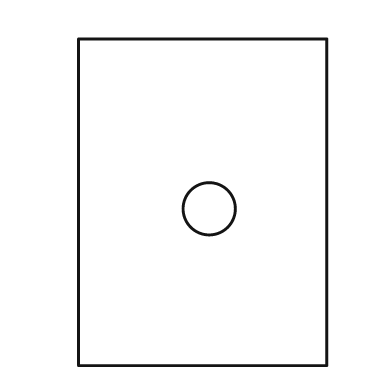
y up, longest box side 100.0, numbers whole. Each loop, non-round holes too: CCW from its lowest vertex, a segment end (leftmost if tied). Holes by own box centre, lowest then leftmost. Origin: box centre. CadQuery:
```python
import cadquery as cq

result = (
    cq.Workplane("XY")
    .moveTo(-38.0, -50.0)
    .lineTo(38.0, -50.0)
    .lineTo(38.0, 50.0)
    .lineTo(-38.0, 50.0)
    .close()
    .moveTo(2.0, -2.0)
    .circle(8.0)
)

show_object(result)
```